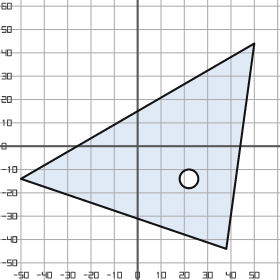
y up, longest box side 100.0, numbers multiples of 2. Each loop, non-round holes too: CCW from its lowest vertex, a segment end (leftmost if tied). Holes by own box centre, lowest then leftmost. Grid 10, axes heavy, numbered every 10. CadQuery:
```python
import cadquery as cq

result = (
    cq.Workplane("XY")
    .moveTo(38.0, -44.0)
    .lineTo(50.0, 44.0)
    .lineTo(-50.0, -14.0)
    .close()
    .moveTo(22.0, -14.0)
    .circle(4.0)
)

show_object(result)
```